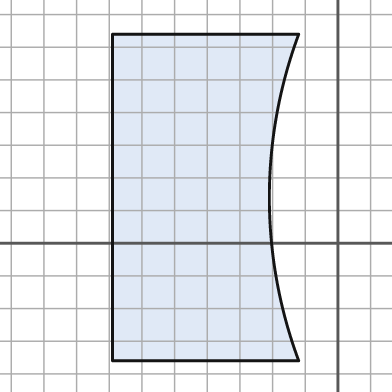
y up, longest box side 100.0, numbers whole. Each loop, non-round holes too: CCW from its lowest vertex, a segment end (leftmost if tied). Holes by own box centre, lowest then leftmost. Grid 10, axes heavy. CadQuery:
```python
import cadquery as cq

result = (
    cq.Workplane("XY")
    .moveTo(-69.0, -36.0)
    .lineTo(-12.0, -36.0)
    .threePointArc((-21.0, 14.0), (-12.0, 64.0))
    .lineTo(-69.0, 64.0)
    .close()
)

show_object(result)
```